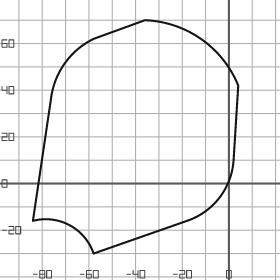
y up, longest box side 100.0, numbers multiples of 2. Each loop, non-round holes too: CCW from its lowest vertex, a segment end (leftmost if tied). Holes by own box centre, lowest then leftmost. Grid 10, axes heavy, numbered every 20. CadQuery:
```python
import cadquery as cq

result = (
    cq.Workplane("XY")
    .moveTo(-58.0, -30.0)
    .lineTo(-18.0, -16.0)
    .threePointArc((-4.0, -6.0), (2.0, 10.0))
    .lineTo(4.0, 42.0)
    .threePointArc((-12.0, 62.0), (-36.0, 70.0))
    .lineTo(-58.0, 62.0)
    .threePointArc((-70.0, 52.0), (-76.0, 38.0))
    .lineTo(-84.0, -16.0)
    .threePointArc((-68.0, -18.0), (-58.0, -30.0))
    .close()
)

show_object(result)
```